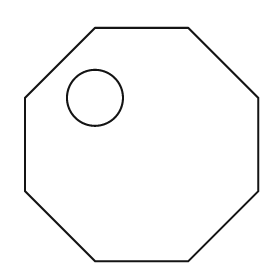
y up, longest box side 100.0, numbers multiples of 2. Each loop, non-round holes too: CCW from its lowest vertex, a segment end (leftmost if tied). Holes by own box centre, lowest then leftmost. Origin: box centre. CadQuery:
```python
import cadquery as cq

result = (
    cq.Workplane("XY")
    .moveTo(-20.0, -50.0)
    .lineTo(20.0, -50.0)
    .lineTo(50.0, -20.0)
    .lineTo(50.0, 20.0)
    .lineTo(20.0, 50.0)
    .lineTo(-20.0, 50.0)
    .lineTo(-50.0, 20.0)
    .lineTo(-50.0, -20.0)
    .close()
    .moveTo(-20.0, 20.0)
    .circle(12.0)
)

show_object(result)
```